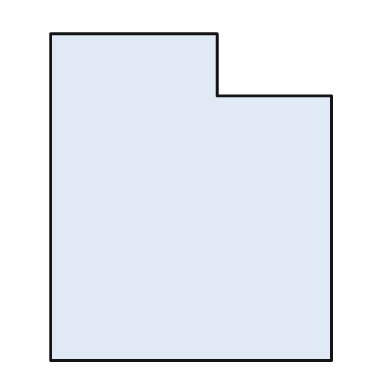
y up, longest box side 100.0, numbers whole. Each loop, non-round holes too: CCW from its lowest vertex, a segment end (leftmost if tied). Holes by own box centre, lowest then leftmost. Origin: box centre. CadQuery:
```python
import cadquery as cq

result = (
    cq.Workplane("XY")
    .moveTo(-43.0, -50.0)
    .lineTo(43.0, -50.0)
    .lineTo(43.0, 31.0)
    .lineTo(8.0, 31.0)
    .lineTo(8.0, 50.0)
    .lineTo(-43.0, 50.0)
    .close()
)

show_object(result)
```